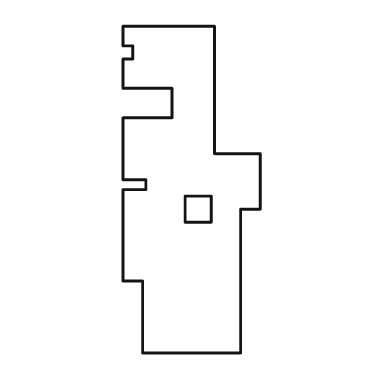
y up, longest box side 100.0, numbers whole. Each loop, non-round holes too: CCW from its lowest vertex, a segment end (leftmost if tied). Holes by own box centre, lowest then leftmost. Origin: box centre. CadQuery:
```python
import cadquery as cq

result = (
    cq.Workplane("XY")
    .moveTo(-15.0, -50.0)
    .lineTo(15.0, -50.0)
    .lineTo(15.0, -6.0)
    .lineTo(21.0, -6.0)
    .lineTo(21.0, 11.0)
    .lineTo(7.0, 11.0)
    .lineTo(7.0, 50.0)
    .lineTo(-21.0, 50.0)
    .lineTo(-21.0, 44.0)
    .lineTo(-18.0, 44.0)
    .lineTo(-18.0, 40.0)
    .lineTo(-21.0, 40.0)
    .lineTo(-21.0, 31.0)
    .lineTo(-6.0, 31.0)
    .lineTo(-6.0, 22.0)
    .lineTo(-21.0, 22.0)
    .lineTo(-21.0, 3.0)
    .lineTo(-14.0, 3.0)
    .lineTo(-14.0, 0.0)
    .lineTo(-21.0, 0.0)
    .lineTo(-21.0, -28.0)
    .lineTo(-15.0, -28.0)
    .close()
    .moveTo(-2.0, -10.0)
    .lineTo(6.0, -10.0)
    .lineTo(6.0, -2.0)
    .lineTo(-2.0, -2.0)
    .close()
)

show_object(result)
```